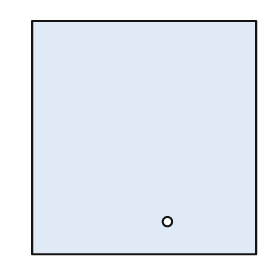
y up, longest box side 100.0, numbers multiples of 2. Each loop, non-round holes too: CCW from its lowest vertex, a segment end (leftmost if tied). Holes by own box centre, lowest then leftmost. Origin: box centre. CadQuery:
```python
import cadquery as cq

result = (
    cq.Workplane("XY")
    .moveTo(-48.0, -50.0)
    .lineTo(48.0, -50.0)
    .lineTo(48.0, 50.0)
    .lineTo(-48.0, 50.0)
    .close()
    .moveTo(10.0, -36.0)
    .circle(2.0)
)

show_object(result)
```